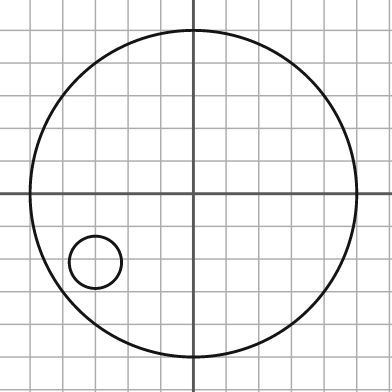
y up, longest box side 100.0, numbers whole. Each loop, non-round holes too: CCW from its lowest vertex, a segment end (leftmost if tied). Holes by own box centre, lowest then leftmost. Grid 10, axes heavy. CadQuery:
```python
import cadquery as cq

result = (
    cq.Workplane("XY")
    .moveTo(0.0, 0.0)
    .circle(50.0)
    .moveTo(-30.0, -21.0)
    .circle(8.0)
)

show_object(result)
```